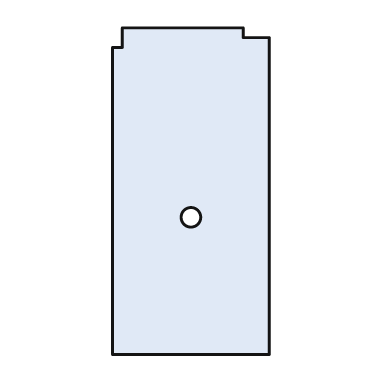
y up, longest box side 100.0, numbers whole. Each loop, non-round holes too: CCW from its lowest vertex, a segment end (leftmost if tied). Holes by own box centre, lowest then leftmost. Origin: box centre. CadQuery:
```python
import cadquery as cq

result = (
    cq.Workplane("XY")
    .moveTo(-24.0, -50.0)
    .lineTo(24.0, -50.0)
    .lineTo(24.0, 47.0)
    .lineTo(16.0, 47.0)
    .lineTo(16.0, 50.0)
    .lineTo(-21.0, 50.0)
    .lineTo(-21.0, 44.0)
    .lineTo(-24.0, 44.0)
    .close()
    .moveTo(0.0, -8.0)
    .circle(3.0)
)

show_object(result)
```